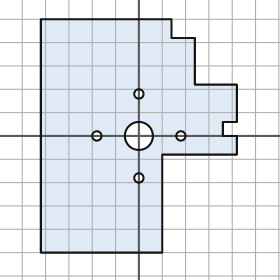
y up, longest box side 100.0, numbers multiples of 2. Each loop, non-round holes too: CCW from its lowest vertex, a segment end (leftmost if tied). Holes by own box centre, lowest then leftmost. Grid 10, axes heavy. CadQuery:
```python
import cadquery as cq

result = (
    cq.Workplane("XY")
    .moveTo(-42.0, -50.0)
    .lineTo(10.0, -50.0)
    .lineTo(10.0, -8.0)
    .lineTo(42.0, -8.0)
    .lineTo(42.0, 0.0)
    .lineTo(36.0, 0.0)
    .lineTo(36.0, 6.0)
    .lineTo(42.0, 6.0)
    .lineTo(42.0, 22.0)
    .lineTo(24.0, 22.0)
    .lineTo(24.0, 42.0)
    .lineTo(14.0, 42.0)
    .lineTo(14.0, 50.0)
    .lineTo(-42.0, 50.0)
    .close()
    .moveTo(0.0, -18.0)
    .circle(2.0)
    .moveTo(-18.0, 0.0)
    .circle(2.0)
    .moveTo(0.0, 0.0)
    .circle(6.0)
    .moveTo(18.0, 0.0)
    .circle(2.0)
    .moveTo(0.0, 18.0)
    .circle(2.0)
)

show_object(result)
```